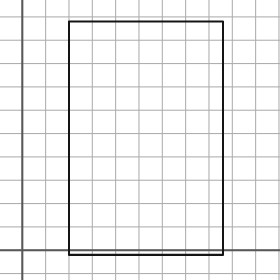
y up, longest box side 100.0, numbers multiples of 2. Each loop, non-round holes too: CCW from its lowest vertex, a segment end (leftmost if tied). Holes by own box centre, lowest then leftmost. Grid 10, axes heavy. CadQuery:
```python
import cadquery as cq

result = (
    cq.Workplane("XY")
    .moveTo(20.0, -2.0)
    .lineTo(86.0, -2.0)
    .lineTo(86.0, 98.0)
    .lineTo(20.0, 98.0)
    .close()
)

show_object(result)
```